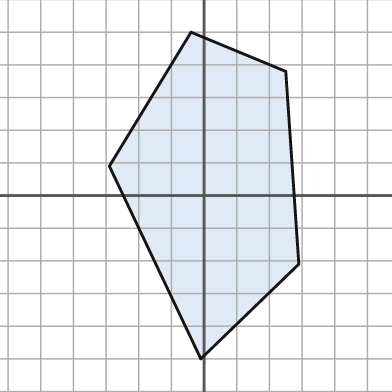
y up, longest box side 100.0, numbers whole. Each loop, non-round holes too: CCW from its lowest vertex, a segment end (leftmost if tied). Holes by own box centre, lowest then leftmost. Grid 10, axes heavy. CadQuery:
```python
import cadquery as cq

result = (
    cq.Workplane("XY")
    .moveTo(-1.0, -50.0)
    .lineTo(29.0, -21.0)
    .lineTo(25.0, 38.0)
    .lineTo(-4.0, 50.0)
    .lineTo(-29.0, 9.0)
    .close()
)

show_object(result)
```